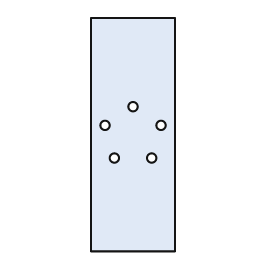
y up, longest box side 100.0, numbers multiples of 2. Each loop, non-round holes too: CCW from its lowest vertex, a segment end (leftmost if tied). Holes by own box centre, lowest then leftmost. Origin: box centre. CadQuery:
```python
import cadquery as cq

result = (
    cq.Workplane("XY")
    .moveTo(-18.0, -50.0)
    .lineTo(18.0, -50.0)
    .lineTo(18.0, 50.0)
    .lineTo(-18.0, 50.0)
    .close()
    .moveTo(-8.0, -10.0)
    .circle(2.0)
    .moveTo(8.0, -10.0)
    .circle(2.0)
    .moveTo(-12.0, 4.0)
    .circle(2.0)
    .moveTo(12.0, 4.0)
    .circle(2.0)
    .moveTo(0.0, 12.0)
    .circle(2.0)
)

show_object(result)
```